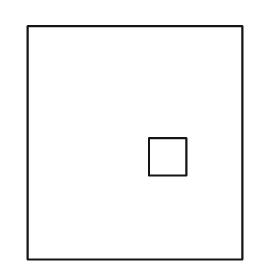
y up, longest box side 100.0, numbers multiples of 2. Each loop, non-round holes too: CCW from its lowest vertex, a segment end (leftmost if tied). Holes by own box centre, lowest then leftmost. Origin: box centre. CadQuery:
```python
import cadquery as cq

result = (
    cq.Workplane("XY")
    .moveTo(-46.0, -50.0)
    .lineTo(46.0, -50.0)
    .lineTo(46.0, 50.0)
    .lineTo(-46.0, 50.0)
    .close()
    .moveTo(6.0, -14.0)
    .lineTo(22.0, -14.0)
    .lineTo(22.0, 2.0)
    .lineTo(6.0, 2.0)
    .close()
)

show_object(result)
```